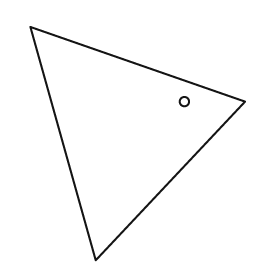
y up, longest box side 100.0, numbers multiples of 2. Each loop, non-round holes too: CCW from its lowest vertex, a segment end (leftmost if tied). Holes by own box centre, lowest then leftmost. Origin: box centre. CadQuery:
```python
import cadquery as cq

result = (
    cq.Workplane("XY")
    .moveTo(-18.0, -50.0)
    .lineTo(46.0, 18.0)
    .lineTo(-46.0, 50.0)
    .close()
    .moveTo(20.0, 18.0)
    .circle(2.0)
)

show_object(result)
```